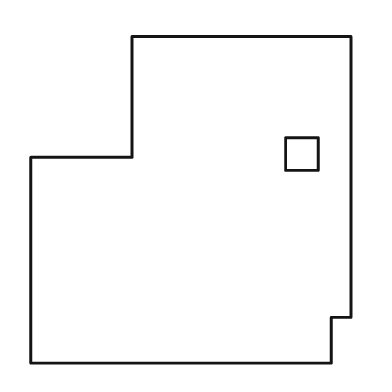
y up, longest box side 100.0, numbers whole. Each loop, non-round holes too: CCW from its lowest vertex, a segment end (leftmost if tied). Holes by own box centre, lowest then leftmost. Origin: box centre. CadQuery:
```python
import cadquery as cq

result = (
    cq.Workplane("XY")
    .moveTo(-49.0, -50.0)
    .lineTo(43.0, -50.0)
    .lineTo(43.0, -36.0)
    .lineTo(49.0, -36.0)
    .lineTo(49.0, 50.0)
    .lineTo(-18.0, 50.0)
    .lineTo(-18.0, 13.0)
    .lineTo(-49.0, 13.0)
    .close()
    .moveTo(29.0, 9.0)
    .lineTo(39.0, 9.0)
    .lineTo(39.0, 19.0)
    .lineTo(29.0, 19.0)
    .close()
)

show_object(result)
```